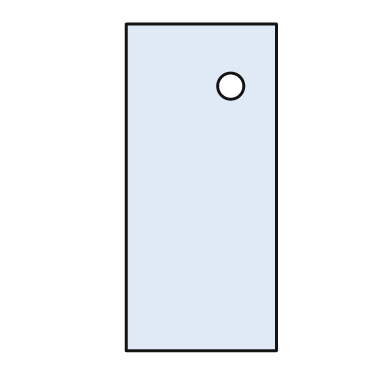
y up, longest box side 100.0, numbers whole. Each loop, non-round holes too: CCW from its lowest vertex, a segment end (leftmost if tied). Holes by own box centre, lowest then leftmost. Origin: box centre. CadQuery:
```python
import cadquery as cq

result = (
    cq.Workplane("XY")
    .moveTo(-23.0, -50.0)
    .lineTo(23.0, -50.0)
    .lineTo(23.0, 50.0)
    .lineTo(-23.0, 50.0)
    .close()
    .moveTo(9.0, 31.0)
    .circle(4.0)
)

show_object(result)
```